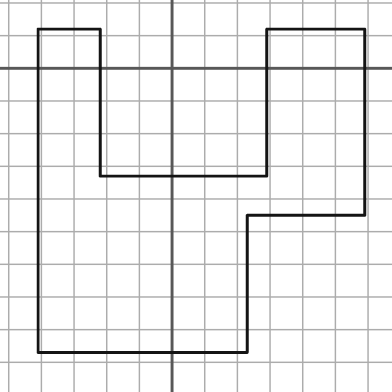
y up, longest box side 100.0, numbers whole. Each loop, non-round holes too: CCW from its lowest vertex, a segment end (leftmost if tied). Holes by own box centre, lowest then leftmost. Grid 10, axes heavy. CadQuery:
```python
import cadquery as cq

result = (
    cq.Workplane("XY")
    .moveTo(-41.0, -87.0)
    .lineTo(23.0, -87.0)
    .lineTo(23.0, -45.0)
    .lineTo(59.0, -45.0)
    .lineTo(59.0, 12.0)
    .lineTo(29.0, 12.0)
    .lineTo(29.0, -33.0)
    .lineTo(-22.0, -33.0)
    .lineTo(-22.0, 12.0)
    .lineTo(-41.0, 12.0)
    .close()
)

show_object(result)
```